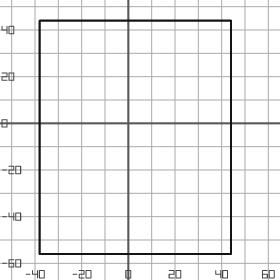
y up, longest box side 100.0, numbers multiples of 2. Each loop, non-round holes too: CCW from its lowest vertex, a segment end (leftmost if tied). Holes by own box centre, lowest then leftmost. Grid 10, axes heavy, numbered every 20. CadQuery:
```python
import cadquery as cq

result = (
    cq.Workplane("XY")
    .moveTo(-38.0, -56.0)
    .lineTo(44.0, -56.0)
    .lineTo(44.0, 44.0)
    .lineTo(-38.0, 44.0)
    .close()
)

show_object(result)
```